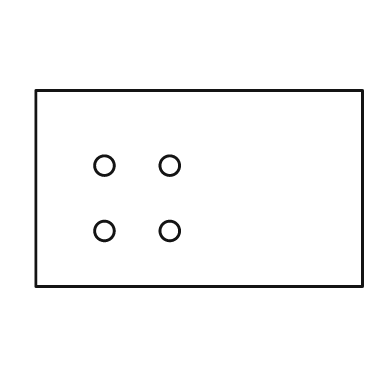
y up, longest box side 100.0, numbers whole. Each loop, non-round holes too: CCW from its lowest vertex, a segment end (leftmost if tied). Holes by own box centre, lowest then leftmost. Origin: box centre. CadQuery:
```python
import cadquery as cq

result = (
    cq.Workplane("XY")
    .moveTo(-50.0, -30.0)
    .lineTo(50.0, -30.0)
    .lineTo(50.0, 30.0)
    .lineTo(-50.0, 30.0)
    .close()
    .moveTo(-29.0, -13.0)
    .circle(3.0)
    .moveTo(-9.0, -13.0)
    .circle(3.0)
    .moveTo(-29.0, 7.0)
    .circle(3.0)
    .moveTo(-9.0, 7.0)
    .circle(3.0)
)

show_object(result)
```